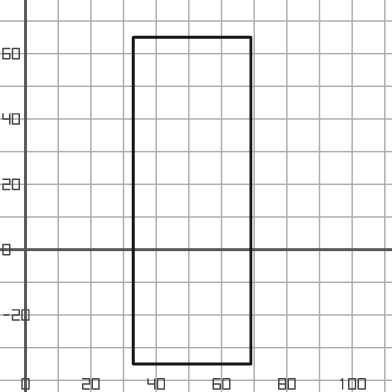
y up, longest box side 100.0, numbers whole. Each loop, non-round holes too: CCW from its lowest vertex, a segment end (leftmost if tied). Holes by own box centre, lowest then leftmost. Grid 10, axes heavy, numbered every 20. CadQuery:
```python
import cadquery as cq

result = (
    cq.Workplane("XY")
    .moveTo(33.0, -35.0)
    .lineTo(69.0, -35.0)
    .lineTo(69.0, 65.0)
    .lineTo(33.0, 65.0)
    .close()
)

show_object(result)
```